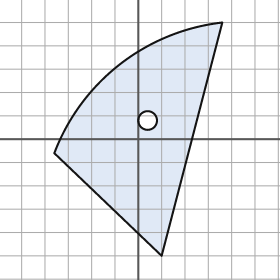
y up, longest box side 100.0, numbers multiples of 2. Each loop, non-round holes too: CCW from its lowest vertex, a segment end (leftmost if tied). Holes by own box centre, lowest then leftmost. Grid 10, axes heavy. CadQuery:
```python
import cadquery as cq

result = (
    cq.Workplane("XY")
    .moveTo(10.0, -50.0)
    .lineTo(36.0, 50.0)
    .threePointArc((-8.0, 32.0), (-36.0, -6.0))
    .close()
    .moveTo(4.0, 8.0)
    .circle(4.0)
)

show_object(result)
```